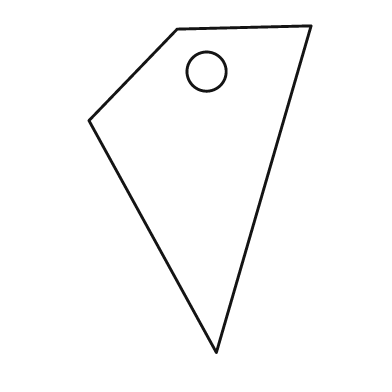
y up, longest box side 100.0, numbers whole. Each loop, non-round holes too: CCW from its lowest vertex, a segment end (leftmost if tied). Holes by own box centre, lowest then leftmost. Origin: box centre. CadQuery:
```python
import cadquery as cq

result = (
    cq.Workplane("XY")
    .moveTo(5.0, -50.0)
    .lineTo(34.0, 50.0)
    .lineTo(-7.0, 49.0)
    .lineTo(-34.0, 21.0)
    .close()
    .moveTo(2.0, 36.0)
    .circle(6.0)
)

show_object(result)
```